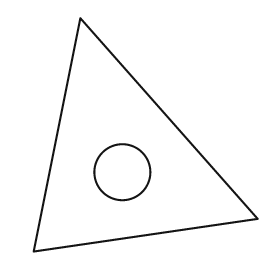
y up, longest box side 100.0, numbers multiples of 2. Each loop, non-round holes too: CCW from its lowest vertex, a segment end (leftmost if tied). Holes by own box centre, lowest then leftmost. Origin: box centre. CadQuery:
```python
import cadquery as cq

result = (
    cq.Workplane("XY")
    .moveTo(-48.0, -50.0)
    .lineTo(48.0, -36.0)
    .lineTo(-28.0, 50.0)
    .close()
    .moveTo(-10.0, -16.0)
    .circle(12.0)
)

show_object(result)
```